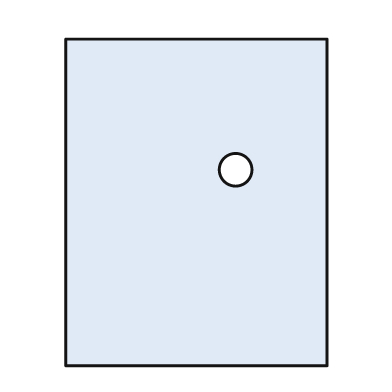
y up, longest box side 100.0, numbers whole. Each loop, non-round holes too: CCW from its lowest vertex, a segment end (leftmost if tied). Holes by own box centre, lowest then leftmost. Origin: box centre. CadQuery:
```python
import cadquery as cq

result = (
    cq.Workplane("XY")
    .moveTo(-40.0, -50.0)
    .lineTo(40.0, -50.0)
    .lineTo(40.0, 50.0)
    .lineTo(-40.0, 50.0)
    .close()
    .moveTo(12.0, 10.0)
    .circle(5.0)
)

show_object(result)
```